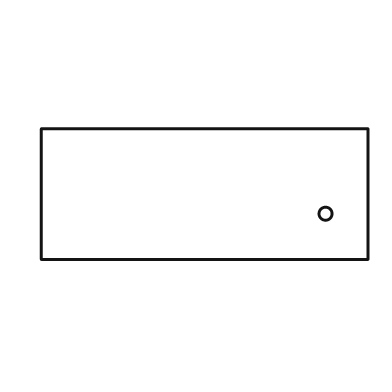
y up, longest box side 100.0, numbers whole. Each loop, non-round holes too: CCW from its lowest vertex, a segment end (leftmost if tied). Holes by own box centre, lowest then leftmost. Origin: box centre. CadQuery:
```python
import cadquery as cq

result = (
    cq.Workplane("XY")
    .moveTo(-50.0, -20.0)
    .lineTo(50.0, -20.0)
    .lineTo(50.0, 20.0)
    .lineTo(-50.0, 20.0)
    .close()
    .moveTo(37.0, -6.0)
    .circle(2.0)
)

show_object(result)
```